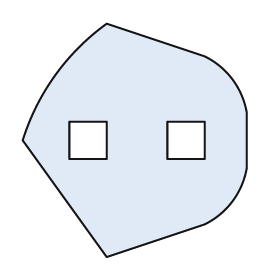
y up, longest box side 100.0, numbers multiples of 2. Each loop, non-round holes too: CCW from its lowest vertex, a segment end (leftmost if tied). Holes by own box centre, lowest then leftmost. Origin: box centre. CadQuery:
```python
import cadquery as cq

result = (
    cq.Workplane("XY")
    .moveTo(-12.0, -50.0)
    .lineTo(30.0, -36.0)
    .threePointArc((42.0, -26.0), (48.0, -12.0))
    .lineTo(48.0, 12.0)
    .threePointArc((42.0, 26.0), (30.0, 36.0))
    .lineTo(-12.0, 50.0)
    .threePointArc((-34.0, 28.0), (-48.0, 0.0))
    .close()
    .moveTo(-28.0, -8.0)
    .lineTo(-12.0, -8.0)
    .lineTo(-12.0, 8.0)
    .lineTo(-28.0, 8.0)
    .close()
    .moveTo(14.0, -8.0)
    .lineTo(30.0, -8.0)
    .lineTo(30.0, 8.0)
    .lineTo(14.0, 8.0)
    .close()
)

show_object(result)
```